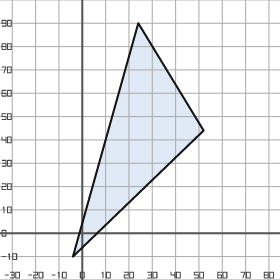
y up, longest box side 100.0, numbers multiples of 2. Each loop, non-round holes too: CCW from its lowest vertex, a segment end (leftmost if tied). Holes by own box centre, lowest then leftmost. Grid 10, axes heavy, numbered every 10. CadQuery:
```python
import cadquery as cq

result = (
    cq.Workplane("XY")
    .moveTo(-4.0, -10.0)
    .lineTo(52.0, 44.0)
    .lineTo(24.0, 90.0)
    .close()
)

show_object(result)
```